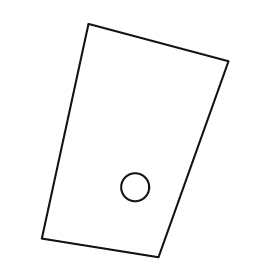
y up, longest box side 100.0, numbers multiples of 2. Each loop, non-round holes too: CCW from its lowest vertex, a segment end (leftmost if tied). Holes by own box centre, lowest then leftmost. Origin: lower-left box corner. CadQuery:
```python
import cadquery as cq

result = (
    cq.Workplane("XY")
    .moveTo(50.0, 0.0)
    .lineTo(80.0, 84.0)
    .lineTo(20.0, 100.0)
    .lineTo(0.0, 8.0)
    .close()
    .moveTo(40.0, 30.0)
    .circle(6.0)
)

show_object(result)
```